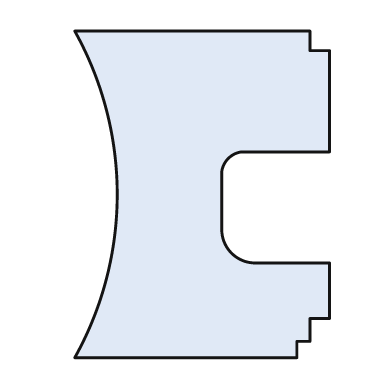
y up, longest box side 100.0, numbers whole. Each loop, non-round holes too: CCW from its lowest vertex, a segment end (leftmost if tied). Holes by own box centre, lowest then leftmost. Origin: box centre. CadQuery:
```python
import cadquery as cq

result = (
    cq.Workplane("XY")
    .moveTo(-39.0, -50.0)
    .lineTo(29.0, -50.0)
    .lineTo(29.0, -45.0)
    .lineTo(33.0, -45.0)
    .lineTo(33.0, -38.0)
    .lineTo(39.0, -38.0)
    .lineTo(39.0, -21.0)
    .lineTo(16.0, -21.0)
    .threePointArc((9.0, -18.0), (6.0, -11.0))
    .lineTo(6.0, 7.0)
    .threePointArc((8.0, 11.0), (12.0, 13.0))
    .lineTo(39.0, 13.0)
    .lineTo(39.0, 44.0)
    .lineTo(33.0, 44.0)
    .lineTo(33.0, 50.0)
    .lineTo(-39.0, 50.0)
    .threePointArc((-26.0, 0.0), (-39.0, -50.0))
    .close()
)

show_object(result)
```